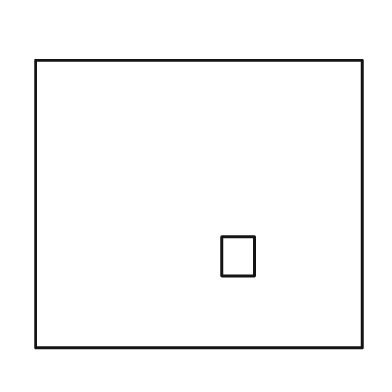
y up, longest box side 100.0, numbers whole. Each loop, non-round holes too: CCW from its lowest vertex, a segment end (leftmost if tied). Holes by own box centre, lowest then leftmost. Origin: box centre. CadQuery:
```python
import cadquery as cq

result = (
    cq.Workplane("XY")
    .moveTo(-50.0, -44.0)
    .lineTo(50.0, -44.0)
    .lineTo(50.0, 44.0)
    .lineTo(-50.0, 44.0)
    .close()
    .moveTo(7.0, -22.0)
    .lineTo(17.0, -22.0)
    .lineTo(17.0, -10.0)
    .lineTo(7.0, -10.0)
    .close()
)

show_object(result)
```